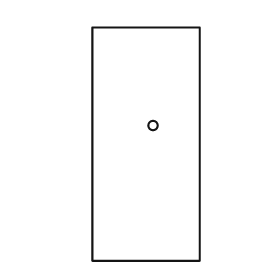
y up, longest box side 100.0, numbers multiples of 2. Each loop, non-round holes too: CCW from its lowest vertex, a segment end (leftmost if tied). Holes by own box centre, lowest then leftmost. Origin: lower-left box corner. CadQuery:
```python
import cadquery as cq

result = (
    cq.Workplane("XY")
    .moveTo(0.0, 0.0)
    .lineTo(46.0, 0.0)
    .lineTo(46.0, 100.0)
    .lineTo(0.0, 100.0)
    .close()
    .moveTo(26.0, 58.0)
    .circle(2.0)
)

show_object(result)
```